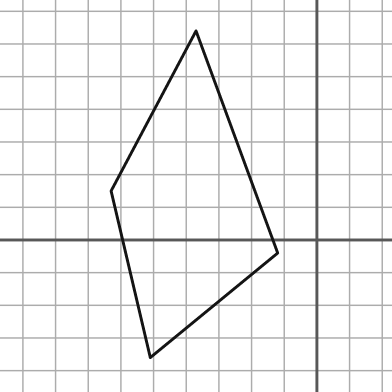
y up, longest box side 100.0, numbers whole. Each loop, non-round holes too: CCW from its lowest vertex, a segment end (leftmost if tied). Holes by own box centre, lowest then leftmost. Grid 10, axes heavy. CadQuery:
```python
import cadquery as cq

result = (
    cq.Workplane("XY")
    .moveTo(-51.0, -36.0)
    .lineTo(-12.0, -4.0)
    .lineTo(-37.0, 64.0)
    .lineTo(-63.0, 15.0)
    .close()
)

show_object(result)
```